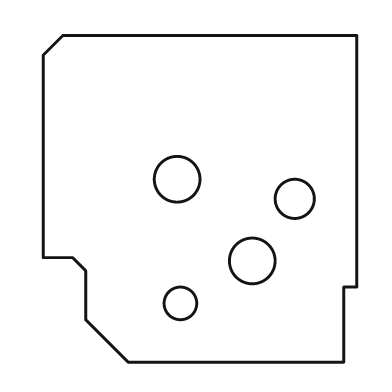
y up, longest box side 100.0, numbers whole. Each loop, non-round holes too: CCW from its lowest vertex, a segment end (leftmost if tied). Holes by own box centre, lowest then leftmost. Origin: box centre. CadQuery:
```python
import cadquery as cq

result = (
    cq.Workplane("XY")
    .moveTo(-22.0, -50.0)
    .lineTo(44.0, -50.0)
    .lineTo(44.0, -27.0)
    .lineTo(48.0, -27.0)
    .lineTo(48.0, 50.0)
    .lineTo(-42.0, 50.0)
    .lineTo(-48.0, 44.0)
    .lineTo(-48.0, -18.0)
    .lineTo(-39.0, -18.0)
    .lineTo(-35.0, -22.0)
    .lineTo(-35.0, -37.0)
    .close()
    .moveTo(-6.0, -32.0)
    .circle(5.0)
    .moveTo(16.0, -19.0)
    .circle(7.0)
    .moveTo(29.0, 0.0)
    .circle(6.0)
    .moveTo(-7.0, 6.0)
    .circle(7.0)
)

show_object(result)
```